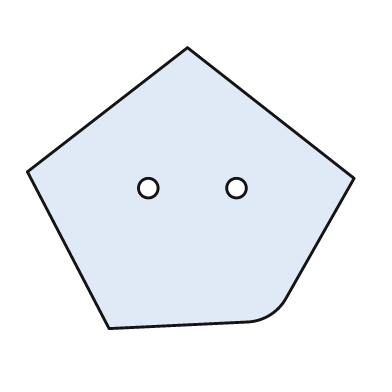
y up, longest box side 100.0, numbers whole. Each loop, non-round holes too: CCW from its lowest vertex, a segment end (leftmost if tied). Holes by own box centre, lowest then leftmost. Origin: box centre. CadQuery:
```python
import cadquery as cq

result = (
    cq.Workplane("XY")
    .moveTo(-25.0, -43.0)
    .lineTo(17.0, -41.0)
    .threePointArc((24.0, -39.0), (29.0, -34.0))
    .lineTo(50.0, 3.0)
    .lineTo(-1.0, 43.0)
    .lineTo(-50.0, 5.0)
    .close()
    .moveTo(-13.0, 0.0)
    .circle(3.0)
    .moveTo(14.0, 0.0)
    .circle(3.0)
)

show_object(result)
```